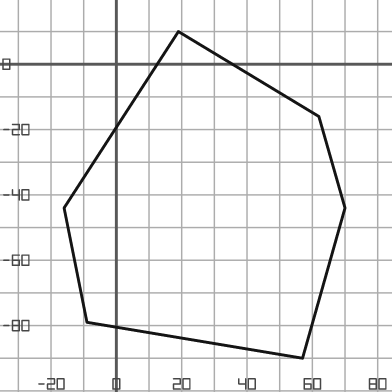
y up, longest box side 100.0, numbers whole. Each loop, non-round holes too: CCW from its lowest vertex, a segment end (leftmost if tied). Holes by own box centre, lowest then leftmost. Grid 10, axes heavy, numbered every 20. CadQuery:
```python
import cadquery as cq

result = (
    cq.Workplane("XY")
    .moveTo(57.0, -90.0)
    .lineTo(70.0, -44.0)
    .lineTo(62.0, -16.0)
    .lineTo(19.0, 10.0)
    .lineTo(-16.0, -44.0)
    .lineTo(-9.0, -79.0)
    .close()
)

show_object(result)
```